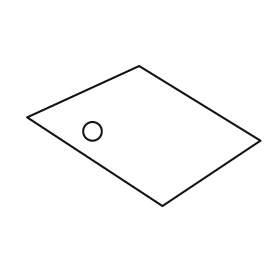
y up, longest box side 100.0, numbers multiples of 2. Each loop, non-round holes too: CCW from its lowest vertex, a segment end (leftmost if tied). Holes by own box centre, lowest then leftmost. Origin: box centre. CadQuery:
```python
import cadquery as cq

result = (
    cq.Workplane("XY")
    .moveTo(8.0, -30.0)
    .lineTo(50.0, -2.0)
    .lineTo(-2.0, 30.0)
    .lineTo(-50.0, 8.0)
    .close()
    .moveTo(-22.0, 2.0)
    .circle(4.0)
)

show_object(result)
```